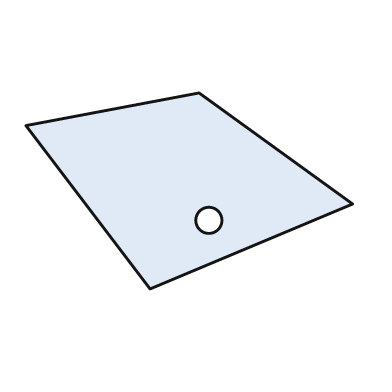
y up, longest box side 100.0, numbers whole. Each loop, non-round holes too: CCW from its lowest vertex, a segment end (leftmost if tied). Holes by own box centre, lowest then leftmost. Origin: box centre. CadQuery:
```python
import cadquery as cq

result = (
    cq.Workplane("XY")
    .moveTo(-12.0, -30.0)
    .lineTo(50.0, -4.0)
    .lineTo(3.0, 30.0)
    .lineTo(-50.0, 20.0)
    .close()
    .moveTo(6.0, -9.0)
    .circle(4.0)
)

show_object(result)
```